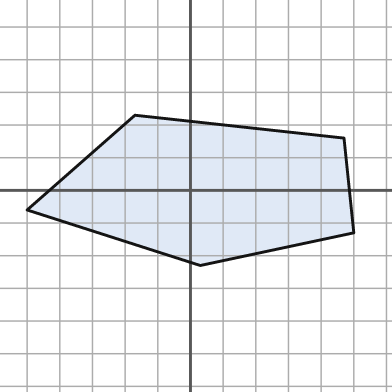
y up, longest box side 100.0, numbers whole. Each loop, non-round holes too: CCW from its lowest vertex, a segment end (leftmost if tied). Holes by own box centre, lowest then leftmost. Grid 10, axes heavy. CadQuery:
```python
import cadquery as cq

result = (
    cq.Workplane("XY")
    .moveTo(3.0, -23.0)
    .lineTo(50.0, -13.0)
    .lineTo(47.0, 16.0)
    .lineTo(-17.0, 23.0)
    .lineTo(-50.0, -6.0)
    .close()
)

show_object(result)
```